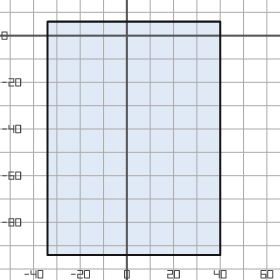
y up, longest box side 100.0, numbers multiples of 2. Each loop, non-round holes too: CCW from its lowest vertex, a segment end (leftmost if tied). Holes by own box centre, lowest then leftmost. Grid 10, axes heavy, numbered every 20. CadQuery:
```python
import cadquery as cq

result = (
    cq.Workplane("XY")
    .moveTo(-34.0, -94.0)
    .lineTo(40.0, -94.0)
    .lineTo(40.0, 6.0)
    .lineTo(-34.0, 6.0)
    .close()
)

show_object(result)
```